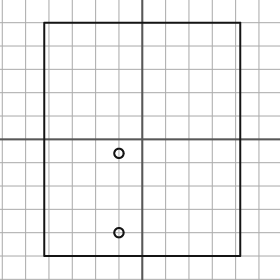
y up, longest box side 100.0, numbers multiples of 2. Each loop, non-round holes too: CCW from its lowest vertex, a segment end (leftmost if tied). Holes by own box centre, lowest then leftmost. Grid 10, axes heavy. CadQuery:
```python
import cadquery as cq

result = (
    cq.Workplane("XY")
    .moveTo(-42.0, -50.0)
    .lineTo(42.0, -50.0)
    .lineTo(42.0, 50.0)
    .lineTo(-42.0, 50.0)
    .close()
    .moveTo(-10.0, -40.0)
    .circle(2.0)
    .moveTo(-10.0, -6.0)
    .circle(2.0)
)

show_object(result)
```